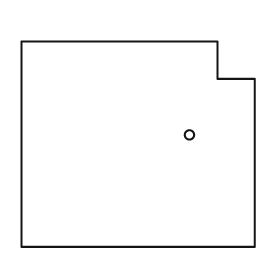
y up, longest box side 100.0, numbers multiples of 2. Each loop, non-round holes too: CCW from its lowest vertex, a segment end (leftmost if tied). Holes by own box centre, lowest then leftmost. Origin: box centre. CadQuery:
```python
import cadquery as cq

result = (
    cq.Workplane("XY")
    .moveTo(-50.0, -44.0)
    .lineTo(50.0, -44.0)
    .lineTo(50.0, 28.0)
    .lineTo(34.0, 28.0)
    .lineTo(34.0, 44.0)
    .lineTo(-50.0, 44.0)
    .close()
    .moveTo(22.0, 4.0)
    .circle(2.0)
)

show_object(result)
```